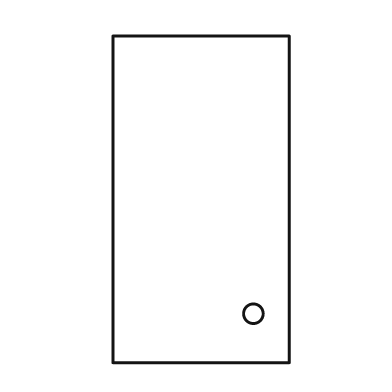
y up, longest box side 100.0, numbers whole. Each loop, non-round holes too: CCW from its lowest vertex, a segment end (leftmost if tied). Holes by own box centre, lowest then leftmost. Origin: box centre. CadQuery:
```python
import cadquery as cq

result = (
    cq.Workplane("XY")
    .moveTo(-27.0, -50.0)
    .lineTo(27.0, -50.0)
    .lineTo(27.0, 50.0)
    .lineTo(-27.0, 50.0)
    .close()
    .moveTo(16.0, -35.0)
    .circle(3.0)
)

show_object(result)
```